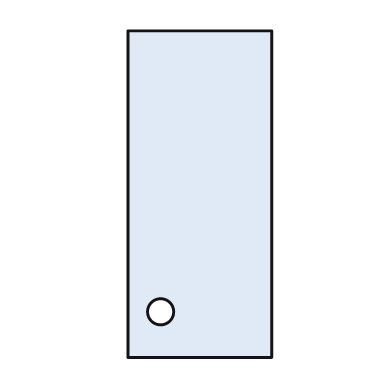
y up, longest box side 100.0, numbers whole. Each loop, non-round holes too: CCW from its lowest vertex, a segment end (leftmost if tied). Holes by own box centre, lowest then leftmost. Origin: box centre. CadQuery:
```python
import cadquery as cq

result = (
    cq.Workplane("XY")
    .moveTo(-22.0, -50.0)
    .lineTo(22.0, -50.0)
    .lineTo(22.0, 50.0)
    .lineTo(-22.0, 50.0)
    .close()
    .moveTo(-12.0, -36.0)
    .circle(4.0)
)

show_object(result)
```